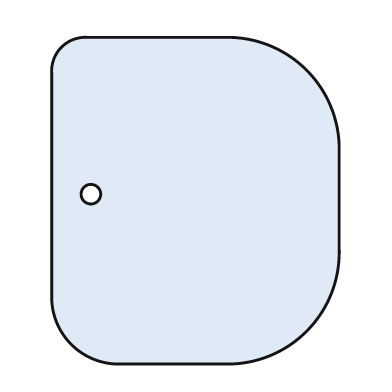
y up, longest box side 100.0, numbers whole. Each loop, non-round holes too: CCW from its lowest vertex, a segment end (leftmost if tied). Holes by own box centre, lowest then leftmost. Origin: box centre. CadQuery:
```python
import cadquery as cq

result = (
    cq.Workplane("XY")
    .moveTo(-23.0, -50.0)
    .lineTo(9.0, -50.0)
    .threePointArc((34.0, -40.0), (44.0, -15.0))
    .lineTo(44.0, 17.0)
    .threePointArc((34.0, 40.0), (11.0, 50.0))
    .lineTo(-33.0, 50.0)
    .threePointArc((-41.0, 47.0), (-44.0, 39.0))
    .lineTo(-44.0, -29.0)
    .threePointArc((-38.0, -44.0), (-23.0, -50.0))
    .close()
    .moveTo(-32.0, 2.0)
    .circle(3.0)
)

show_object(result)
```